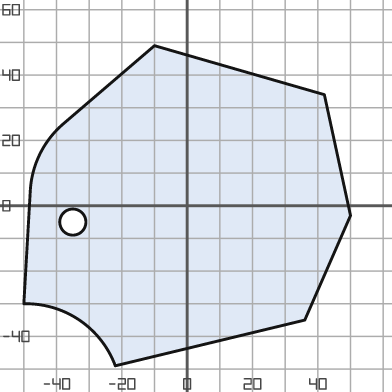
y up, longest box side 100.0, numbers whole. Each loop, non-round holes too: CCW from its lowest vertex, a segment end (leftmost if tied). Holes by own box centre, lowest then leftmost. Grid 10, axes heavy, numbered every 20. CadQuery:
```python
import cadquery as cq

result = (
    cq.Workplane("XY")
    .moveTo(-22.0, -49.0)
    .lineTo(36.0, -35.0)
    .lineTo(50.0, -3.0)
    .lineTo(42.0, 34.0)
    .lineTo(-10.0, 49.0)
    .lineTo(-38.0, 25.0)
    .threePointArc((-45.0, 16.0), (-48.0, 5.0))
    .lineTo(-50.0, -30.0)
    .threePointArc((-33.0, -35.0), (-22.0, -49.0))
    .close()
    .moveTo(-35.0, -5.0)
    .circle(4.0)
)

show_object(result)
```